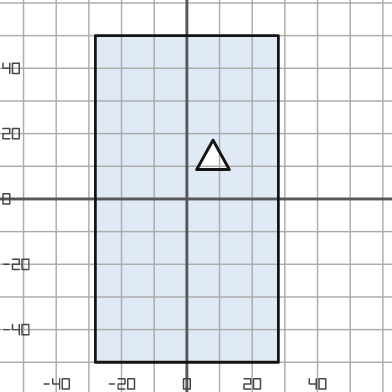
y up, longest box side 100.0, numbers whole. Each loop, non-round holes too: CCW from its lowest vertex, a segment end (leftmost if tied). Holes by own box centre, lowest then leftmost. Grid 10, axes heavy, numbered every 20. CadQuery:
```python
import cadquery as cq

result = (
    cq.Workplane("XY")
    .moveTo(-28.0, -50.0)
    .lineTo(28.0, -50.0)
    .lineTo(28.0, 50.0)
    .lineTo(-28.0, 50.0)
    .close()
    .moveTo(3.0, 9.0)
    .lineTo(13.0, 9.0)
    .lineTo(8.0, 18.0)
    .close()
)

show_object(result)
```